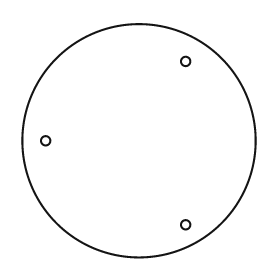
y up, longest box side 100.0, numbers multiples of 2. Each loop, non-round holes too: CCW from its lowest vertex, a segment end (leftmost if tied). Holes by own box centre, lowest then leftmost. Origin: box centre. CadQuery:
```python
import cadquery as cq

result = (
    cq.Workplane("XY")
    .moveTo(0.0, 0.0)
    .circle(50.0)
    .moveTo(20.0, -36.0)
    .circle(2.0)
    .moveTo(-40.0, 0.0)
    .circle(2.0)
    .moveTo(20.0, 34.0)
    .circle(2.0)
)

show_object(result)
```